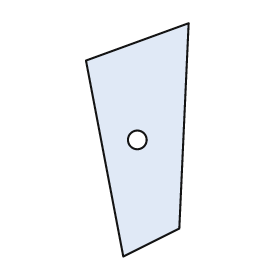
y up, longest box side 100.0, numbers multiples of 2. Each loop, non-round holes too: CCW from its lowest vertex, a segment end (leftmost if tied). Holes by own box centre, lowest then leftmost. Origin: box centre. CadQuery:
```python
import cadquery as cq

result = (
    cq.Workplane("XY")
    .moveTo(-6.0, -50.0)
    .lineTo(18.0, -38.0)
    .lineTo(22.0, 50.0)
    .lineTo(-22.0, 34.0)
    .close()
    .moveTo(0.0, 0.0)
    .circle(4.0)
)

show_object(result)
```